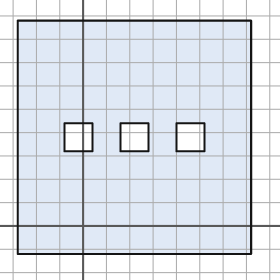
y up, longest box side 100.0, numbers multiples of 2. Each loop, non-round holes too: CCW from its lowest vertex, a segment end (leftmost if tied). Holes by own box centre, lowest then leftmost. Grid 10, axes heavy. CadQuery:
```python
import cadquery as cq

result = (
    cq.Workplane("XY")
    .moveTo(-28.0, -12.0)
    .lineTo(72.0, -12.0)
    .lineTo(72.0, 88.0)
    .lineTo(-28.0, 88.0)
    .close()
    .moveTo(-8.0, 32.0)
    .lineTo(4.0, 32.0)
    .lineTo(4.0, 44.0)
    .lineTo(-8.0, 44.0)
    .close()
    .moveTo(16.0, 32.0)
    .lineTo(28.0, 32.0)
    .lineTo(28.0, 44.0)
    .lineTo(16.0, 44.0)
    .close()
    .moveTo(40.0, 32.0)
    .lineTo(52.0, 32.0)
    .lineTo(52.0, 44.0)
    .lineTo(40.0, 44.0)
    .close()
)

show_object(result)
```